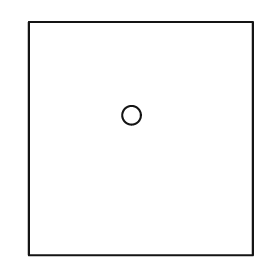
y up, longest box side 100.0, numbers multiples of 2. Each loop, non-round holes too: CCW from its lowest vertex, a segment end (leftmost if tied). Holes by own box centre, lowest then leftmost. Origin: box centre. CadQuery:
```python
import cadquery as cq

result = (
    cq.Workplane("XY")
    .moveTo(-48.0, -50.0)
    .lineTo(48.0, -50.0)
    .lineTo(48.0, 50.0)
    .lineTo(-48.0, 50.0)
    .close()
    .moveTo(-4.0, 10.0)
    .circle(4.0)
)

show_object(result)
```